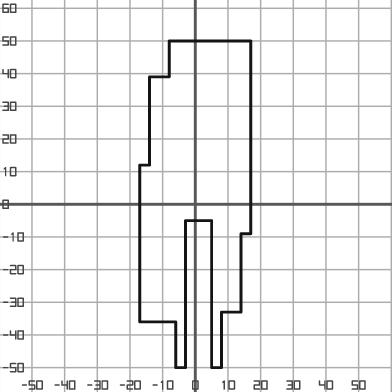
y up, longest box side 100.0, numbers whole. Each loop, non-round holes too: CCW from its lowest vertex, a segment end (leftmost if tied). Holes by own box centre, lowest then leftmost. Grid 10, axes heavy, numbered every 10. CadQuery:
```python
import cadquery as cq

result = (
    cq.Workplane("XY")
    .moveTo(-6.0, -50.0)
    .lineTo(-3.0, -50.0)
    .lineTo(-3.0, -5.0)
    .lineTo(5.0, -5.0)
    .lineTo(5.0, -50.0)
    .lineTo(8.0, -50.0)
    .lineTo(8.0, -33.0)
    .lineTo(14.0, -33.0)
    .lineTo(14.0, -9.0)
    .lineTo(17.0, -9.0)
    .lineTo(17.0, 50.0)
    .lineTo(-8.0, 50.0)
    .lineTo(-8.0, 39.0)
    .lineTo(-14.0, 39.0)
    .lineTo(-14.0, 12.0)
    .lineTo(-17.0, 12.0)
    .lineTo(-17.0, -36.0)
    .lineTo(-6.0, -36.0)
    .close()
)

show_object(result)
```